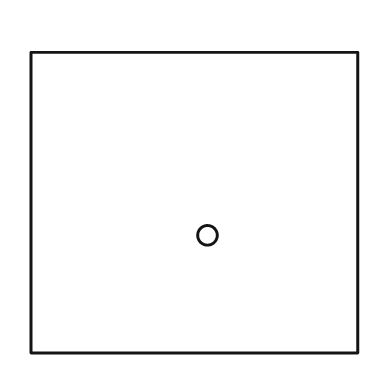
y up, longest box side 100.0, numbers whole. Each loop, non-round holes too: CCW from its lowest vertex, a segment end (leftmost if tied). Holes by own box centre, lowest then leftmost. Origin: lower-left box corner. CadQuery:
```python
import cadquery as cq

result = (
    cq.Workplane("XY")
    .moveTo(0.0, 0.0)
    .lineTo(100.0, 0.0)
    .lineTo(100.0, 92.0)
    .lineTo(0.0, 92.0)
    .close()
    .moveTo(54.0, 36.0)
    .circle(3.0)
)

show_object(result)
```